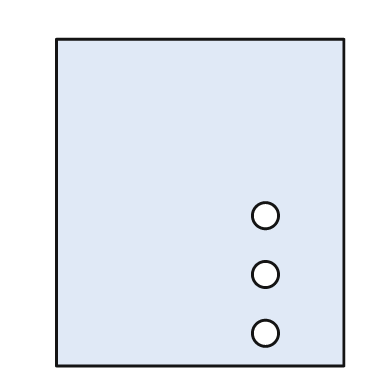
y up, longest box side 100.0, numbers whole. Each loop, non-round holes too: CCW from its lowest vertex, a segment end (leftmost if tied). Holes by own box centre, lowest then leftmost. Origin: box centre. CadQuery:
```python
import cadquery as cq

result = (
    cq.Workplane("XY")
    .moveTo(-44.0, -50.0)
    .lineTo(44.0, -50.0)
    .lineTo(44.0, 50.0)
    .lineTo(-44.0, 50.0)
    .close()
    .moveTo(20.0, -40.0)
    .circle(4.0)
    .moveTo(20.0, -22.0)
    .circle(4.0)
    .moveTo(20.0, -4.0)
    .circle(4.0)
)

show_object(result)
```